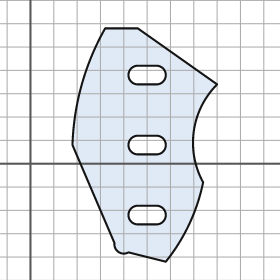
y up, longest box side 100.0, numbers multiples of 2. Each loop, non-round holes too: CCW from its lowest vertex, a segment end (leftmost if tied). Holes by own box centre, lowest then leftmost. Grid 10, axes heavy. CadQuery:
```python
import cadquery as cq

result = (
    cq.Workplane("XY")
    .moveTo(58.0, -42.0)
    .threePointArc((68.0, -26.0), (74.0, -8.0))
    .threePointArc((70.0, 14.0), (80.0, 34.0))
    .lineTo(46.0, 58.0)
    .lineTo(32.0, 58.0)
    .threePointArc((22.0, 34.0), (18.0, 8.0))
    .lineTo(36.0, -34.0)
    .threePointArc((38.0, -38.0), (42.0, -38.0))
    .close()
    .moveTo(46.0, -26.0)
    .lineTo(54.0, -26.0)
    .threePointArc((58.0, -22.0), (54.0, -18.0))
    .lineTo(46.0, -18.0)
    .threePointArc((42.0, -22.0), (46.0, -26.0))
    .close()
    .moveTo(46.0, 4.0)
    .lineTo(54.0, 4.0)
    .threePointArc((58.0, 8.0), (54.0, 12.0))
    .lineTo(46.0, 12.0)
    .threePointArc((42.0, 8.0), (46.0, 4.0))
    .close()
    .moveTo(46.0, 34.0)
    .lineTo(54.0, 34.0)
    .threePointArc((58.0, 38.0), (54.0, 42.0))
    .lineTo(46.0, 42.0)
    .threePointArc((42.0, 38.0), (46.0, 34.0))
    .close()
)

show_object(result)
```